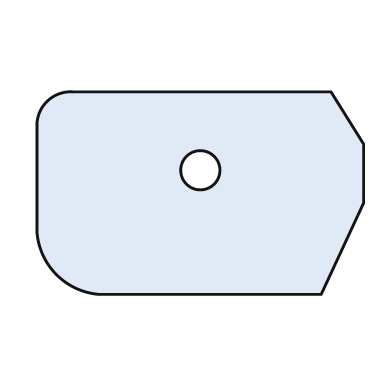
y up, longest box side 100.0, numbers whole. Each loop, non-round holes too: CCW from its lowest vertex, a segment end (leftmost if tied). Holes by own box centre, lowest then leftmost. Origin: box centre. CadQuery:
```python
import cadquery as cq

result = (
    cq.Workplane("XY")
    .moveTo(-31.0, -31.0)
    .lineTo(37.0, -31.0)
    .lineTo(50.0, -3.0)
    .lineTo(50.0, 15.0)
    .lineTo(40.0, 31.0)
    .lineTo(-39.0, 31.0)
    .threePointArc((-47.0, 28.0), (-50.0, 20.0))
    .lineTo(-50.0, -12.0)
    .threePointArc((-44.0, -25.0), (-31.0, -31.0))
    .close()
    .moveTo(0.0, 7.0)
    .circle(6.0)
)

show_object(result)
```